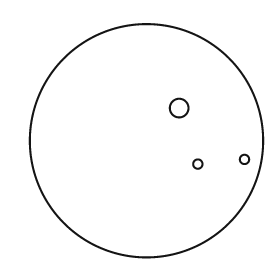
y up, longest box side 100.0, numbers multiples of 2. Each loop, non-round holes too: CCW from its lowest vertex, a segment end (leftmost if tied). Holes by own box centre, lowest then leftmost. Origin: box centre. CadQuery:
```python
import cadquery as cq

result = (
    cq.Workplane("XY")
    .moveTo(0.0, 0.0)
    .circle(50.0)
    .moveTo(22.0, -10.0)
    .circle(2.0)
    .moveTo(42.0, -8.0)
    .circle(2.0)
    .moveTo(14.0, 14.0)
    .circle(4.0)
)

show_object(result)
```